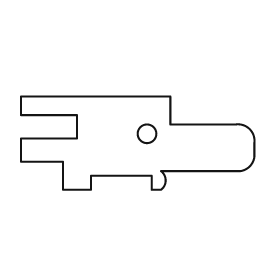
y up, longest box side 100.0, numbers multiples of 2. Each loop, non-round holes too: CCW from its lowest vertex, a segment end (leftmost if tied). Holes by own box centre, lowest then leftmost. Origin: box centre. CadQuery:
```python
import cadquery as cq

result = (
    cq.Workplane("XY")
    .moveTo(-32.0, -20.0)
    .lineTo(-20.0, -20.0)
    .lineTo(-20.0, -14.0)
    .lineTo(6.0, -14.0)
    .lineTo(6.0, -20.0)
    .lineTo(10.0, -20.0)
    .threePointArc((12.0, -16.0), (10.0, -12.0))
    .lineTo(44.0, -12.0)
    .threePointArc((48.0, -10.0), (50.0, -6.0))
    .lineTo(50.0, 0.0)
    .threePointArc((48.0, 6.0), (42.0, 8.0))
    .lineTo(14.0, 8.0)
    .lineTo(14.0, 20.0)
    .lineTo(-50.0, 20.0)
    .lineTo(-50.0, 12.0)
    .lineTo(-26.0, 12.0)
    .lineTo(-26.0, 2.0)
    .lineTo(-50.0, 2.0)
    .lineTo(-50.0, -8.0)
    .lineTo(-32.0, -8.0)
    .close()
    .moveTo(4.0, 4.0)
    .circle(4.0)
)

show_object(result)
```